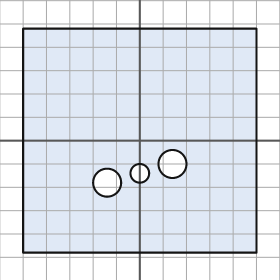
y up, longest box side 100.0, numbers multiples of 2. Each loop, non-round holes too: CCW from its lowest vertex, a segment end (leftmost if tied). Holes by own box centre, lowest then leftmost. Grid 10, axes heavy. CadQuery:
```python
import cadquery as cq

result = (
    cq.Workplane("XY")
    .moveTo(-50.0, -48.0)
    .lineTo(50.0, -48.0)
    .lineTo(50.0, 48.0)
    .lineTo(-50.0, 48.0)
    .close()
    .moveTo(-14.0, -18.0)
    .circle(6.0)
    .moveTo(0.0, -14.0)
    .circle(4.0)
    .moveTo(14.0, -10.0)
    .circle(6.0)
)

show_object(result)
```